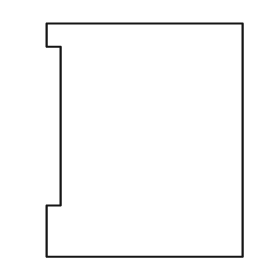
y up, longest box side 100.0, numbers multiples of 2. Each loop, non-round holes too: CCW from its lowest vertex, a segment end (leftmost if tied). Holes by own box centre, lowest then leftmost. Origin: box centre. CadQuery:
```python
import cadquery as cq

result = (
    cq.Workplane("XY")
    .moveTo(-42.0, -50.0)
    .lineTo(42.0, -50.0)
    .lineTo(42.0, 50.0)
    .lineTo(-42.0, 50.0)
    .lineTo(-42.0, 40.0)
    .lineTo(-36.0, 40.0)
    .lineTo(-36.0, -28.0)
    .lineTo(-42.0, -28.0)
    .close()
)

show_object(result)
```